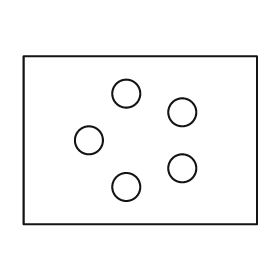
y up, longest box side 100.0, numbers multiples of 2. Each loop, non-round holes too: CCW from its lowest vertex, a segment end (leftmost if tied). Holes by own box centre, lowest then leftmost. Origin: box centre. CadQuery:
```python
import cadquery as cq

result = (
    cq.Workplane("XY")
    .moveTo(-50.0, -36.0)
    .lineTo(50.0, -36.0)
    .lineTo(50.0, 36.0)
    .lineTo(-50.0, 36.0)
    .close()
    .moveTo(-6.0, -20.0)
    .circle(6.0)
    .moveTo(18.0, -12.0)
    .circle(6.0)
    .moveTo(-22.0, 0.0)
    .circle(6.0)
    .moveTo(18.0, 12.0)
    .circle(6.0)
    .moveTo(-6.0, 20.0)
    .circle(6.0)
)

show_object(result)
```